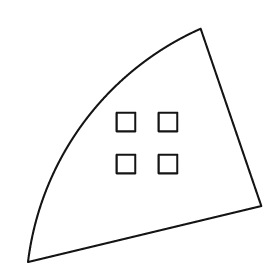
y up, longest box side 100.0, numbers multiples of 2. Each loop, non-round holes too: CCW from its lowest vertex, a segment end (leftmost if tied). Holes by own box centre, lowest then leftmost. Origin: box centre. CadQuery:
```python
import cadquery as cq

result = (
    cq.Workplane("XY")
    .moveTo(-50.0, -50.0)
    .lineTo(50.0, -26.0)
    .lineTo(24.0, 50.0)
    .threePointArc((-26.0, 10.0), (-50.0, -50.0))
    .close()
    .moveTo(-12.0, -12.0)
    .lineTo(-4.0, -12.0)
    .lineTo(-4.0, -4.0)
    .lineTo(-12.0, -4.0)
    .close()
    .moveTo(6.0, -12.0)
    .lineTo(14.0, -12.0)
    .lineTo(14.0, -4.0)
    .lineTo(6.0, -4.0)
    .close()
    .moveTo(-12.0, 6.0)
    .lineTo(-4.0, 6.0)
    .lineTo(-4.0, 14.0)
    .lineTo(-12.0, 14.0)
    .close()
    .moveTo(6.0, 6.0)
    .lineTo(14.0, 6.0)
    .lineTo(14.0, 14.0)
    .lineTo(6.0, 14.0)
    .close()
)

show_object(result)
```